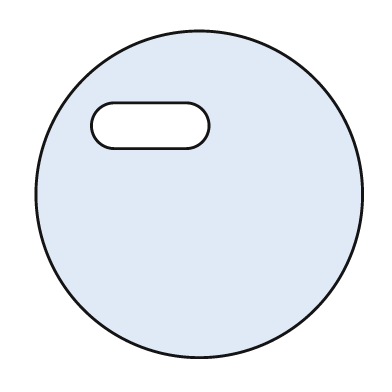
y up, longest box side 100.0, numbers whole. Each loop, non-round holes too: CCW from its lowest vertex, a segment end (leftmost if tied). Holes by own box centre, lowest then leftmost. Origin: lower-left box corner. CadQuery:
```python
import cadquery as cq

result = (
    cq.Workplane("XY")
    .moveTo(50.0, 50.0)
    .circle(50.0)
    .moveTo(24.0, 64.0)
    .lineTo(46.0, 64.0)
    .threePointArc((53.0, 71.0), (46.0, 78.0))
    .lineTo(24.0, 78.0)
    .threePointArc((17.0, 71.0), (24.0, 64.0))
    .close()
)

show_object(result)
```